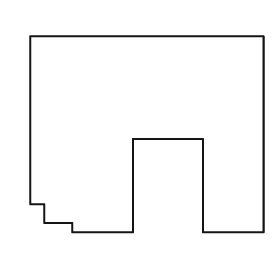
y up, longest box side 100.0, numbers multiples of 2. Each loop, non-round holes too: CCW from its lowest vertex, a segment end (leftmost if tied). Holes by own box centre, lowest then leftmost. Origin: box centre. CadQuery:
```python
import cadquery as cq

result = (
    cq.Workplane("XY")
    .moveTo(-32.0, -42.0)
    .lineTo(-6.0, -42.0)
    .lineTo(-6.0, -2.0)
    .lineTo(24.0, -2.0)
    .lineTo(24.0, -42.0)
    .lineTo(50.0, -42.0)
    .lineTo(50.0, 42.0)
    .lineTo(-50.0, 42.0)
    .lineTo(-50.0, -30.0)
    .lineTo(-44.0, -30.0)
    .lineTo(-44.0, -38.0)
    .lineTo(-32.0, -38.0)
    .close()
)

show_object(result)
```